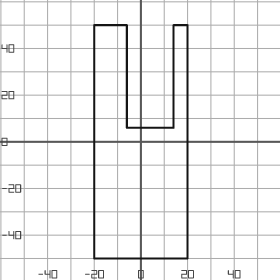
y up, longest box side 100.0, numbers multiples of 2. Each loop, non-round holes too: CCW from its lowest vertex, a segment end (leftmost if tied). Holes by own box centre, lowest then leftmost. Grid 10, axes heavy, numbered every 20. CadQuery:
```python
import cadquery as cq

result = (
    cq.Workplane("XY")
    .moveTo(-20.0, -50.0)
    .lineTo(20.0, -50.0)
    .lineTo(20.0, 50.0)
    .lineTo(14.0, 50.0)
    .lineTo(14.0, 6.0)
    .lineTo(-6.0, 6.0)
    .lineTo(-6.0, 50.0)
    .lineTo(-20.0, 50.0)
    .close()
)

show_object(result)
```